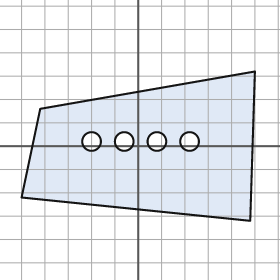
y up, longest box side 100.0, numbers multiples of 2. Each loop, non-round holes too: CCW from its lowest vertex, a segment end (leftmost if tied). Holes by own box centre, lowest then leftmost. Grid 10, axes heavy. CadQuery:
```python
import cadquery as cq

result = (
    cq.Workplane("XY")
    .moveTo(48.0, -32.0)
    .lineTo(50.0, 32.0)
    .lineTo(-42.0, 16.0)
    .lineTo(-50.0, -22.0)
    .close()
    .moveTo(-20.0, 2.0)
    .circle(4.0)
    .moveTo(-6.0, 2.0)
    .circle(4.0)
    .moveTo(8.0, 2.0)
    .circle(4.0)
    .moveTo(22.0, 2.0)
    .circle(4.0)
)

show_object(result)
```